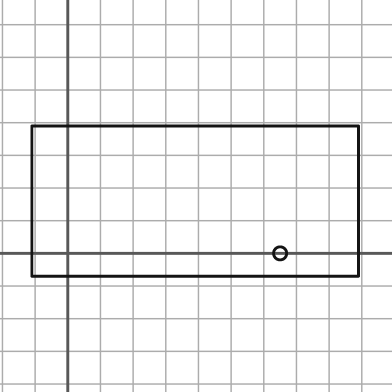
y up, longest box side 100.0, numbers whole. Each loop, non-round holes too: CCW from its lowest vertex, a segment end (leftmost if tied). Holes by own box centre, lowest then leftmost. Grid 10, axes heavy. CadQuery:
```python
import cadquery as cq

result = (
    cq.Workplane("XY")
    .moveTo(-11.0, -7.0)
    .lineTo(89.0, -7.0)
    .lineTo(89.0, 39.0)
    .lineTo(-11.0, 39.0)
    .close()
    .moveTo(65.0, 0.0)
    .circle(2.0)
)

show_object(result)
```